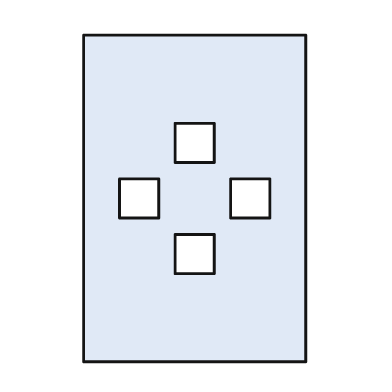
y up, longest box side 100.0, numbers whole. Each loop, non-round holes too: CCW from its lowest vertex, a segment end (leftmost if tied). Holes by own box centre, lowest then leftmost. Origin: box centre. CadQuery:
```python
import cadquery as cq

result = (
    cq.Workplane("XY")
    .moveTo(-34.0, -50.0)
    .lineTo(34.0, -50.0)
    .lineTo(34.0, 50.0)
    .lineTo(-34.0, 50.0)
    .close()
    .moveTo(-6.0, -23.0)
    .lineTo(6.0, -23.0)
    .lineTo(6.0, -11.0)
    .lineTo(-6.0, -11.0)
    .close()
    .moveTo(-23.0, -6.0)
    .lineTo(-11.0, -6.0)
    .lineTo(-11.0, 6.0)
    .lineTo(-23.0, 6.0)
    .close()
    .moveTo(11.0, -6.0)
    .lineTo(23.0, -6.0)
    .lineTo(23.0, 6.0)
    .lineTo(11.0, 6.0)
    .close()
    .moveTo(-6.0, 11.0)
    .lineTo(6.0, 11.0)
    .lineTo(6.0, 23.0)
    .lineTo(-6.0, 23.0)
    .close()
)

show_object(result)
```